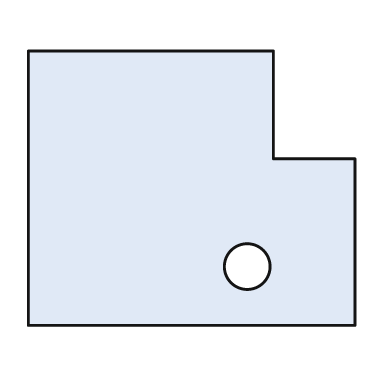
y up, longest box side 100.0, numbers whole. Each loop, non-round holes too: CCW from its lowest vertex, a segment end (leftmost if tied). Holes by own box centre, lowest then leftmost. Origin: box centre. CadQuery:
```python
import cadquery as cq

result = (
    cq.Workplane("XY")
    .moveTo(-50.0, -42.0)
    .lineTo(50.0, -42.0)
    .lineTo(50.0, 9.0)
    .lineTo(25.0, 9.0)
    .lineTo(25.0, 42.0)
    .lineTo(-50.0, 42.0)
    .close()
    .moveTo(17.0, -24.0)
    .circle(7.0)
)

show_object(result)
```